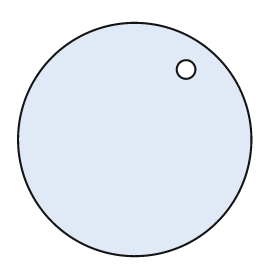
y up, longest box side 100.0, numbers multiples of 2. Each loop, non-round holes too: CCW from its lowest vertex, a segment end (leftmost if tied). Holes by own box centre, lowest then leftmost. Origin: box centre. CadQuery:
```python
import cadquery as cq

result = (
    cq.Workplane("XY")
    .moveTo(0.0, 0.0)
    .circle(50.0)
    .moveTo(22.0, 30.0)
    .circle(4.0)
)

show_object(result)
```